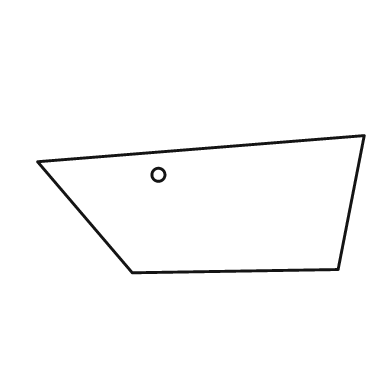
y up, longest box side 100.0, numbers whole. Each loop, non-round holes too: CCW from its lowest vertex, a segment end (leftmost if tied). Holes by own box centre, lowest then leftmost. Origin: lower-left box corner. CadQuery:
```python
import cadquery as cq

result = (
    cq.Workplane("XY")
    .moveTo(29.0, 0.0)
    .lineTo(92.0, 1.0)
    .lineTo(100.0, 42.0)
    .lineTo(0.0, 34.0)
    .close()
    .moveTo(37.0, 30.0)
    .circle(2.0)
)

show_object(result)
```